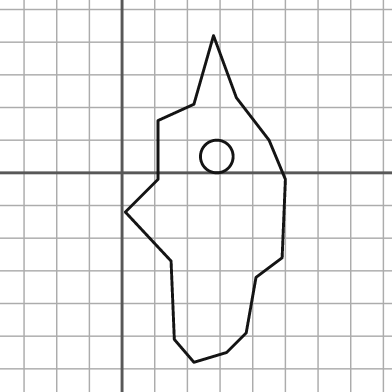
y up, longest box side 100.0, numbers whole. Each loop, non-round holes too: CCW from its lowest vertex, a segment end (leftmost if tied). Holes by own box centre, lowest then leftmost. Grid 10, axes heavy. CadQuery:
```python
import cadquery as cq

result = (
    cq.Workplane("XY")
    .moveTo(22.0, -58.0)
    .lineTo(32.0, -55.0)
    .lineTo(38.0, -49.0)
    .lineTo(41.0, -32.0)
    .lineTo(49.0, -26.0)
    .lineTo(50.0, -2.0)
    .lineTo(45.0, 10.0)
    .lineTo(35.0, 23.0)
    .lineTo(28.0, 42.0)
    .lineTo(22.0, 21.0)
    .lineTo(11.0, 16.0)
    .lineTo(11.0, -2.0)
    .lineTo(1.0, -12.0)
    .lineTo(15.0, -27.0)
    .lineTo(16.0, -51.0)
    .close()
    .moveTo(29.0, 5.0)
    .circle(5.0)
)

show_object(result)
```